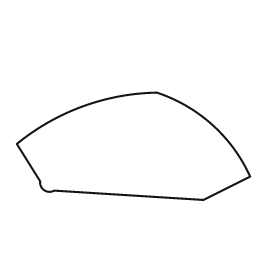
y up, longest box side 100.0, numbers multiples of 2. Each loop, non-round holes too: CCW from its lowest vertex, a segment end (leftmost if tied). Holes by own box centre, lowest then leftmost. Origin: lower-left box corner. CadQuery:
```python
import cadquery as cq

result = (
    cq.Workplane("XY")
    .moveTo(80.0, 0.0)
    .lineTo(100.0, 10.0)
    .threePointArc((84.0, 32.0), (60.0, 46.0))
    .threePointArc((28.0, 40.0), (0.0, 24.0))
    .lineTo(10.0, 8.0)
    .threePointArc((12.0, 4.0), (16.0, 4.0))
    .close()
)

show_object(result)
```